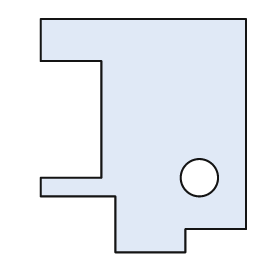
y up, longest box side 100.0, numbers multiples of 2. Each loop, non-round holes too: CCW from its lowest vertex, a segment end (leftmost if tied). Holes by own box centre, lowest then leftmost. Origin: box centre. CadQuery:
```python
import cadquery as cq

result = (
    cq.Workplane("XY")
    .moveTo(-12.0, -50.0)
    .lineTo(18.0, -50.0)
    .lineTo(18.0, -40.0)
    .lineTo(44.0, -40.0)
    .lineTo(44.0, 50.0)
    .lineTo(-44.0, 50.0)
    .lineTo(-44.0, 32.0)
    .lineTo(-18.0, 32.0)
    .lineTo(-18.0, -18.0)
    .lineTo(-44.0, -18.0)
    .lineTo(-44.0, -26.0)
    .lineTo(-12.0, -26.0)
    .close()
    .moveTo(24.0, -18.0)
    .circle(8.0)
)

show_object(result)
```